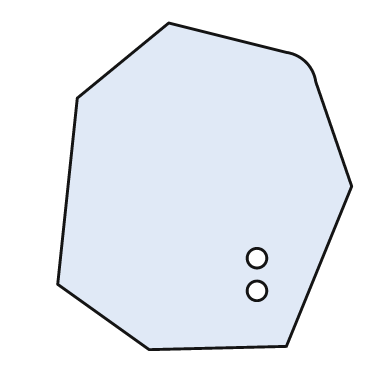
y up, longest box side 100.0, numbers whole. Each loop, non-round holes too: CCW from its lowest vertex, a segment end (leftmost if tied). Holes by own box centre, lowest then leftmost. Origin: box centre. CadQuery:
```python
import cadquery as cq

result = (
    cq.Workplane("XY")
    .moveTo(-17.0, -50.0)
    .lineTo(25.0, -49.0)
    .lineTo(45.0, 0.0)
    .lineTo(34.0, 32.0)
    .threePointArc((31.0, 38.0), (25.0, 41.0))
    .lineTo(-11.0, 50.0)
    .lineTo(-39.0, 27.0)
    .lineTo(-45.0, -30.0)
    .close()
    .moveTo(16.0, -32.0)
    .circle(3.0)
    .moveTo(16.0, -22.0)
    .circle(3.0)
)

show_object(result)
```